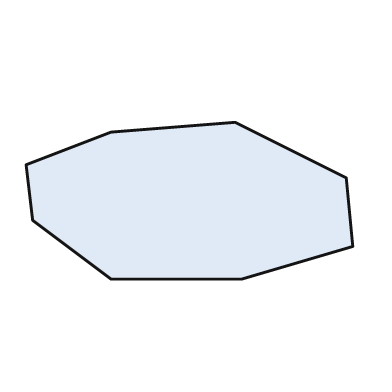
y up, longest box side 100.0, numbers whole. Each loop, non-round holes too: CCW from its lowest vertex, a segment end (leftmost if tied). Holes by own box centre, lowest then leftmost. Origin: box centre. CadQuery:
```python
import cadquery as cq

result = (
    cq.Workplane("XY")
    .moveTo(-24.0, -24.0)
    .lineTo(16.0, -24.0)
    .lineTo(50.0, -14.0)
    .lineTo(48.0, 7.0)
    .lineTo(14.0, 24.0)
    .lineTo(-24.0, 21.0)
    .lineTo(-50.0, 11.0)
    .lineTo(-48.0, -6.0)
    .close()
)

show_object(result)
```